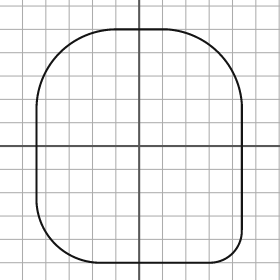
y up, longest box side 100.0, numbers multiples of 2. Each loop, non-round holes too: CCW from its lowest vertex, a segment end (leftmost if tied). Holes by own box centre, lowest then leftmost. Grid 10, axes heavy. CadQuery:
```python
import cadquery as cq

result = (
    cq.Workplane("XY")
    .moveTo(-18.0, -50.0)
    .lineTo(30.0, -50.0)
    .threePointArc((40.0, -46.0), (44.0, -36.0))
    .lineTo(44.0, 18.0)
    .threePointArc((34.0, 40.0), (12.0, 50.0))
    .lineTo(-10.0, 50.0)
    .threePointArc((-34.0, 40.0), (-44.0, 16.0))
    .lineTo(-44.0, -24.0)
    .threePointArc((-36.0, -42.0), (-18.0, -50.0))
    .close()
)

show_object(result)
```